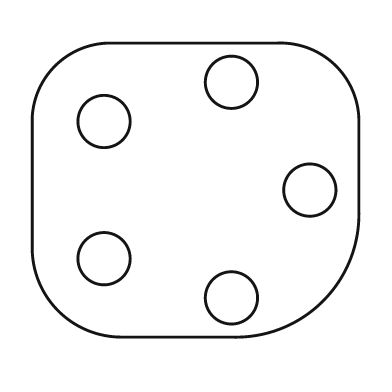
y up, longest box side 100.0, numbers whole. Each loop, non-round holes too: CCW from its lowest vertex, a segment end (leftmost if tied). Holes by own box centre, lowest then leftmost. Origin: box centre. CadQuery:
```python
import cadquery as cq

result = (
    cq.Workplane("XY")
    .moveTo(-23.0, -45.0)
    .lineTo(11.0, -45.0)
    .threePointArc((39.0, -34.0), (50.0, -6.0))
    .lineTo(50.0, 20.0)
    .threePointArc((43.0, 38.0), (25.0, 45.0))
    .lineTo(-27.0, 45.0)
    .threePointArc((-43.0, 38.0), (-50.0, 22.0))
    .lineTo(-50.0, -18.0)
    .threePointArc((-42.0, -37.0), (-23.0, -45.0))
    .close()
    .moveTo(11.0, -33.0)
    .circle(8.0)
    .moveTo(-28.0, -21.0)
    .circle(8.0)
    .moveTo(35.0, 0.0)
    .circle(8.0)
    .moveTo(-28.0, 21.0)
    .circle(8.0)
    .moveTo(11.0, 33.0)
    .circle(8.0)
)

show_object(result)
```